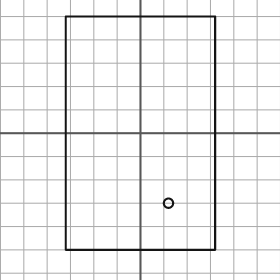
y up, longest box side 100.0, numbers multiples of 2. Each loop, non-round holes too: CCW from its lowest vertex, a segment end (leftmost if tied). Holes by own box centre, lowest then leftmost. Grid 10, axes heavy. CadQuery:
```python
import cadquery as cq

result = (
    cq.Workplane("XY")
    .moveTo(-32.0, -50.0)
    .lineTo(32.0, -50.0)
    .lineTo(32.0, 50.0)
    .lineTo(-32.0, 50.0)
    .close()
    .moveTo(12.0, -30.0)
    .circle(2.0)
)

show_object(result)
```